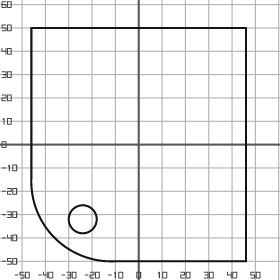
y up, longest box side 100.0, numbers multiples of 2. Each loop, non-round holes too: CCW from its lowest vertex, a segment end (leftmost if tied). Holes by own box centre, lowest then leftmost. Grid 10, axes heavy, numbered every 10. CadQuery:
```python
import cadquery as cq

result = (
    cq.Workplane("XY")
    .moveTo(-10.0, -50.0)
    .lineTo(46.0, -50.0)
    .lineTo(46.0, 50.0)
    .lineTo(-46.0, 50.0)
    .lineTo(-46.0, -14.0)
    .threePointArc((-36.0, -40.0), (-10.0, -50.0))
    .close()
    .moveTo(-24.0, -32.0)
    .circle(6.0)
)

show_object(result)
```